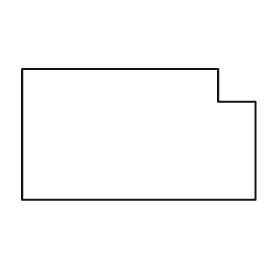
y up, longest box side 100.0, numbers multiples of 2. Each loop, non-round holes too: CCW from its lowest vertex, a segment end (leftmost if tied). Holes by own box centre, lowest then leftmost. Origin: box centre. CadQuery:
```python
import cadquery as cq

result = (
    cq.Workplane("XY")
    .moveTo(-50.0, -28.0)
    .lineTo(50.0, -28.0)
    .lineTo(50.0, 14.0)
    .lineTo(34.0, 14.0)
    .lineTo(34.0, 28.0)
    .lineTo(-50.0, 28.0)
    .close()
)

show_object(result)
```